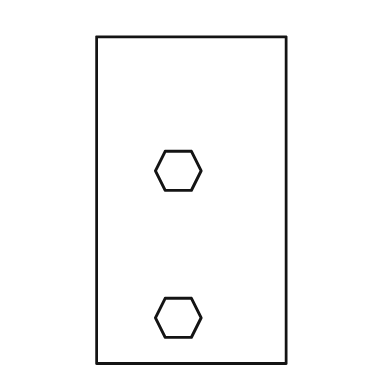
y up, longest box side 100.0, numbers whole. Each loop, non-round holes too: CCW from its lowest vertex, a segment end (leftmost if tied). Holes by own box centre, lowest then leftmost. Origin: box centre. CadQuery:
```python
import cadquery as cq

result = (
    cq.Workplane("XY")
    .moveTo(-29.0, -50.0)
    .lineTo(29.0, -50.0)
    .lineTo(29.0, 50.0)
    .lineTo(-29.0, 50.0)
    .close()
    .moveTo(-8.0, -42.0)
    .lineTo(0.0, -42.0)
    .lineTo(3.0, -36.0)
    .lineTo(0.0, -30.0)
    .lineTo(-8.0, -30.0)
    .lineTo(-11.0, -36.0)
    .close()
    .moveTo(-8.0, 3.0)
    .lineTo(0.0, 3.0)
    .lineTo(3.0, 9.0)
    .lineTo(0.0, 15.0)
    .lineTo(-8.0, 15.0)
    .lineTo(-11.0, 9.0)
    .close()
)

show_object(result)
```